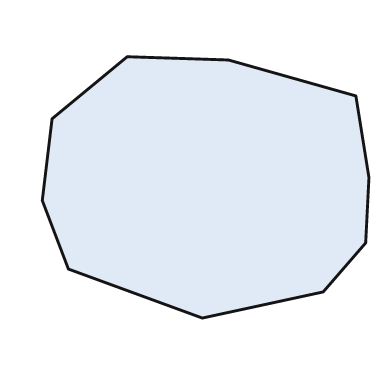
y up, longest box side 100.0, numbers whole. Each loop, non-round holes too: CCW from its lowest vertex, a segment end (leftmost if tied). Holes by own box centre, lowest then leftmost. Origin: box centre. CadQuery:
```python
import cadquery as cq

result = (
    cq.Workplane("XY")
    .moveTo(-1.0, -40.0)
    .lineTo(36.0, -32.0)
    .lineTo(49.0, -17.0)
    .lineTo(50.0, 3.0)
    .lineTo(46.0, 28.0)
    .lineTo(7.0, 39.0)
    .lineTo(-24.0, 40.0)
    .lineTo(-47.0, 21.0)
    .lineTo(-50.0, -4.0)
    .lineTo(-42.0, -25.0)
    .close()
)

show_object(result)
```